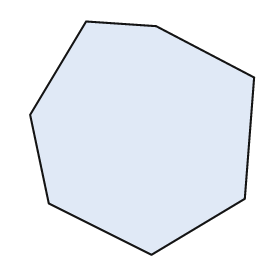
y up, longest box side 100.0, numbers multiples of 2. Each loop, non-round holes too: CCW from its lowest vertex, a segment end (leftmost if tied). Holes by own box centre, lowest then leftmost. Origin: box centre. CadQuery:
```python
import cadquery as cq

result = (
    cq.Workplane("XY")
    .moveTo(4.0, -50.0)
    .lineTo(44.0, -26.0)
    .lineTo(48.0, 26.0)
    .lineTo(6.0, 48.0)
    .lineTo(-24.0, 50.0)
    .lineTo(-48.0, 10.0)
    .lineTo(-40.0, -28.0)
    .close()
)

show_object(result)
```